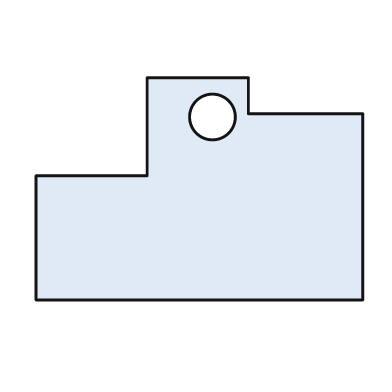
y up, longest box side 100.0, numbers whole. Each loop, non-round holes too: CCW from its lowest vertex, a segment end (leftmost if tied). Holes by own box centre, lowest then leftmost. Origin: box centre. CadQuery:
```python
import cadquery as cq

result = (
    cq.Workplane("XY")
    .moveTo(-50.0, -34.0)
    .lineTo(50.0, -34.0)
    .lineTo(50.0, 23.0)
    .lineTo(15.0, 23.0)
    .lineTo(15.0, 34.0)
    .lineTo(-16.0, 34.0)
    .lineTo(-16.0, 4.0)
    .lineTo(-50.0, 4.0)
    .close()
    .moveTo(4.0, 22.0)
    .circle(7.0)
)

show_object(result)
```